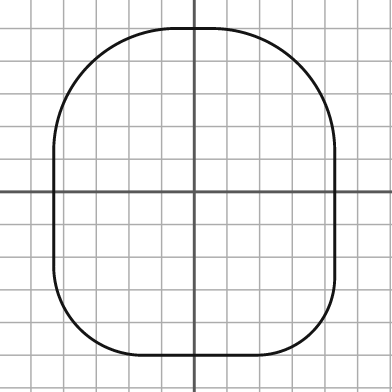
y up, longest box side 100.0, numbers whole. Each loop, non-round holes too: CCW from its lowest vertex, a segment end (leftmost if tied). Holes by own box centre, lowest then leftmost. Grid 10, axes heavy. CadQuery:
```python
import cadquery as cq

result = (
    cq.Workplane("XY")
    .moveTo(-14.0, -50.0)
    .lineTo(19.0, -50.0)
    .threePointArc((36.0, -43.0), (43.0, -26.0))
    .lineTo(43.0, 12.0)
    .threePointArc((32.0, 39.0), (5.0, 50.0))
    .lineTo(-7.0, 50.0)
    .threePointArc((-32.0, 39.0), (-43.0, 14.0))
    .lineTo(-43.0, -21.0)
    .threePointArc((-35.0, -42.0), (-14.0, -50.0))
    .close()
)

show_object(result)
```